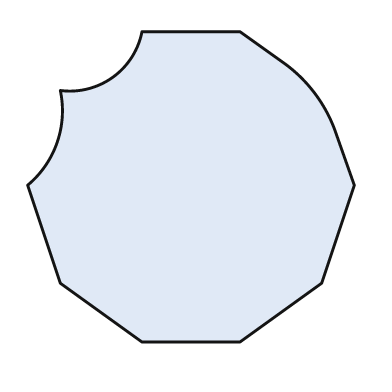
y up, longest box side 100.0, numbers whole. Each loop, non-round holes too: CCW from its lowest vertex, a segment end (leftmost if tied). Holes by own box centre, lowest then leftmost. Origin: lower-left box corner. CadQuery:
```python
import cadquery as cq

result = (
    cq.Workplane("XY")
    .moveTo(35.0, 0.0)
    .lineTo(65.0, 0.0)
    .lineTo(90.0, 18.0)
    .lineTo(100.0, 48.0)
    .lineTo(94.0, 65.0)
    .threePointArc((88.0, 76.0), (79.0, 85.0))
    .lineTo(65.0, 95.0)
    .lineTo(35.0, 95.0)
    .threePointArc((26.0, 81.0), (10.0, 77.0))
    .threePointArc((9.0, 61.0), (0.0, 48.0))
    .lineTo(10.0, 18.0)
    .close()
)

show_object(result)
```